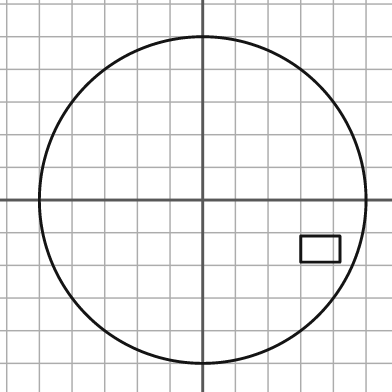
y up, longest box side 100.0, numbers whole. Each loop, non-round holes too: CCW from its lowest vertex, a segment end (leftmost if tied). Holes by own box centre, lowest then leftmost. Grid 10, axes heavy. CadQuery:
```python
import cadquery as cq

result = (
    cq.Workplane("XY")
    .moveTo(0.0, 0.0)
    .circle(50.0)
    .moveTo(30.0, -19.0)
    .lineTo(42.0, -19.0)
    .lineTo(42.0, -11.0)
    .lineTo(30.0, -11.0)
    .close()
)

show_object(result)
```